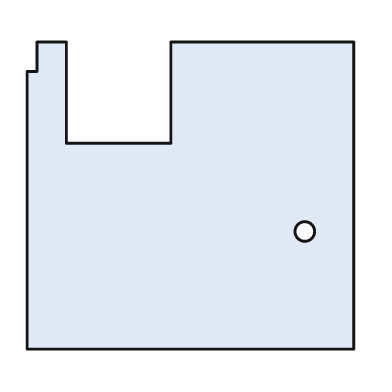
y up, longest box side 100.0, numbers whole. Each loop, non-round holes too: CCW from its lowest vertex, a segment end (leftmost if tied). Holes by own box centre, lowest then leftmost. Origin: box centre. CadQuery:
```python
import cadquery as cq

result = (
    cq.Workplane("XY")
    .moveTo(-50.0, -47.0)
    .lineTo(50.0, -47.0)
    .lineTo(50.0, 47.0)
    .lineTo(-6.0, 47.0)
    .lineTo(-6.0, 16.0)
    .lineTo(-38.0, 16.0)
    .lineTo(-38.0, 47.0)
    .lineTo(-47.0, 47.0)
    .lineTo(-47.0, 38.0)
    .lineTo(-50.0, 38.0)
    .close()
    .moveTo(35.0, -11.0)
    .circle(3.0)
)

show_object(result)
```